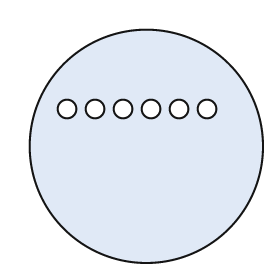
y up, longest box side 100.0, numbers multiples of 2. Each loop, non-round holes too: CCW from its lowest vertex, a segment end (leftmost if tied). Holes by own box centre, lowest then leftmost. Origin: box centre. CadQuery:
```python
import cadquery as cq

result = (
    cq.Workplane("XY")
    .moveTo(0.0, 0.0)
    .circle(50.0)
    .moveTo(-34.0, 16.0)
    .circle(4.0)
    .moveTo(-22.0, 16.0)
    .circle(4.0)
    .moveTo(-10.0, 16.0)
    .circle(4.0)
    .moveTo(2.0, 16.0)
    .circle(4.0)
    .moveTo(14.0, 16.0)
    .circle(4.0)
    .moveTo(26.0, 16.0)
    .circle(4.0)
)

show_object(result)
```